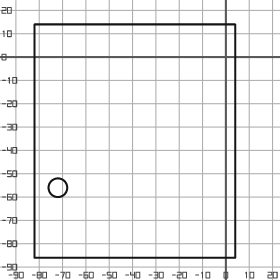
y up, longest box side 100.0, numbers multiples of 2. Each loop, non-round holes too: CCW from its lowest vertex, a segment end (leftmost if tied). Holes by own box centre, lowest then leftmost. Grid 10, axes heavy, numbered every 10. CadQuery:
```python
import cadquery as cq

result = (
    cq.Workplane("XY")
    .moveTo(-82.0, -86.0)
    .lineTo(4.0, -86.0)
    .lineTo(4.0, 14.0)
    .lineTo(-82.0, 14.0)
    .close()
    .moveTo(-72.0, -56.0)
    .circle(4.0)
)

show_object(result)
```